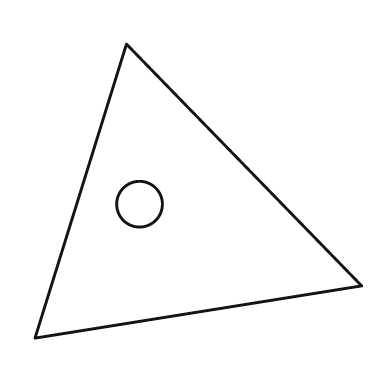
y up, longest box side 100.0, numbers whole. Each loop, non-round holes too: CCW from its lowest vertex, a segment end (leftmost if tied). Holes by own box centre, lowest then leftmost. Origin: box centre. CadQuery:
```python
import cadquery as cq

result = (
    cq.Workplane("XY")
    .moveTo(-50.0, -45.0)
    .lineTo(50.0, -29.0)
    .lineTo(-22.0, 45.0)
    .close()
    .moveTo(-18.0, -4.0)
    .circle(7.0)
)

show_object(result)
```